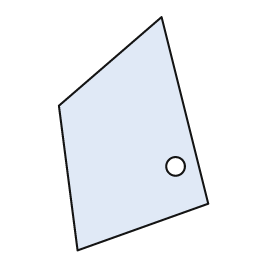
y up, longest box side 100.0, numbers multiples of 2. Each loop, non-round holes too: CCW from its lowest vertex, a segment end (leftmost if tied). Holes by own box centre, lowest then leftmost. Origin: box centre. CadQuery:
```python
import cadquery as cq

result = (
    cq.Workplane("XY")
    .moveTo(-24.0, -50.0)
    .lineTo(32.0, -30.0)
    .lineTo(12.0, 50.0)
    .lineTo(-32.0, 12.0)
    .close()
    .moveTo(18.0, -14.0)
    .circle(4.0)
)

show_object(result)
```